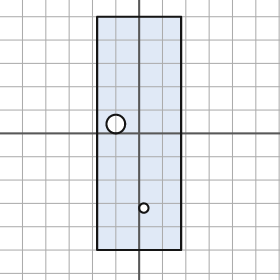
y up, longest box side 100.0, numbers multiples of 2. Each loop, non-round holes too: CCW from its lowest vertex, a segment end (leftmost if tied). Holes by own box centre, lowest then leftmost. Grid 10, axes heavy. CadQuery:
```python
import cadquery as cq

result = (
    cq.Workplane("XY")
    .moveTo(-18.0, -50.0)
    .lineTo(18.0, -50.0)
    .lineTo(18.0, 50.0)
    .lineTo(-18.0, 50.0)
    .close()
    .moveTo(2.0, -32.0)
    .circle(2.0)
    .moveTo(-10.0, 4.0)
    .circle(4.0)
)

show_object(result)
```